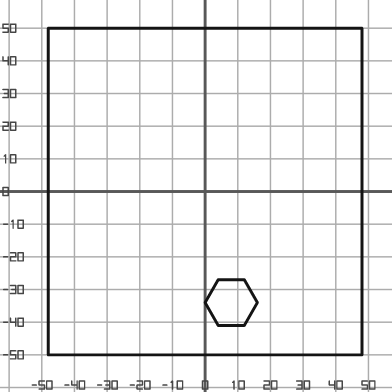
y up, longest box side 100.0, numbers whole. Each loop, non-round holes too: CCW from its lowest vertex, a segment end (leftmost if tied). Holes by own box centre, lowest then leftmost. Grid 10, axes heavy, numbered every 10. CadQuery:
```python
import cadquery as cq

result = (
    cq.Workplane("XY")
    .moveTo(-48.0, -50.0)
    .lineTo(48.0, -50.0)
    .lineTo(48.0, 50.0)
    .lineTo(-48.0, 50.0)
    .close()
    .moveTo(4.0, -41.0)
    .lineTo(12.0, -41.0)
    .lineTo(16.0, -34.0)
    .lineTo(12.0, -27.0)
    .lineTo(4.0, -27.0)
    .lineTo(0.0, -34.0)
    .close()
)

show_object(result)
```